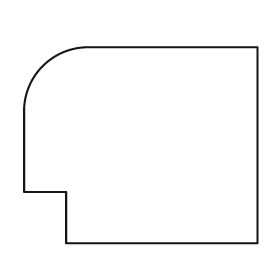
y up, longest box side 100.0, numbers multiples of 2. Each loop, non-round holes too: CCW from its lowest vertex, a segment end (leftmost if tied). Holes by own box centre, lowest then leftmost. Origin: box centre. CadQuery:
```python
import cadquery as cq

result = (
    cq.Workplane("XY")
    .moveTo(-32.0, -42.0)
    .lineTo(50.0, -42.0)
    .lineTo(50.0, 42.0)
    .lineTo(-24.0, 42.0)
    .threePointArc((-42.0, 34.0), (-50.0, 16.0))
    .lineTo(-50.0, -20.0)
    .lineTo(-32.0, -20.0)
    .close()
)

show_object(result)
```